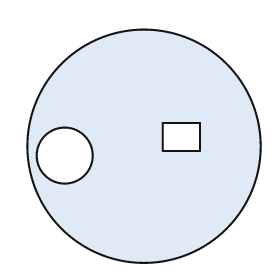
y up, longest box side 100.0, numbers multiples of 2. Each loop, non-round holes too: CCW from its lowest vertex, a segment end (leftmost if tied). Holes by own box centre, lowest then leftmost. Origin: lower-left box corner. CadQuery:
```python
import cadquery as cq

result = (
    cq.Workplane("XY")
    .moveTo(50.0, 50.0)
    .circle(50.0)
    .moveTo(16.0, 46.0)
    .circle(12.0)
    .moveTo(58.0, 48.0)
    .lineTo(74.0, 48.0)
    .lineTo(74.0, 60.0)
    .lineTo(58.0, 60.0)
    .close()
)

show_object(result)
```